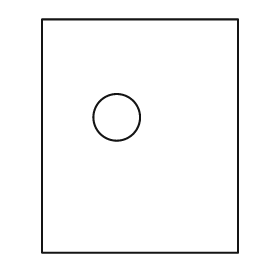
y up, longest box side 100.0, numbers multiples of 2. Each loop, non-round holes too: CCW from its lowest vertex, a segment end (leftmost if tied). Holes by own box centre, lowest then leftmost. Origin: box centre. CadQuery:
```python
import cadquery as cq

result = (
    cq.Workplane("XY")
    .moveTo(-42.0, -50.0)
    .lineTo(42.0, -50.0)
    .lineTo(42.0, 50.0)
    .lineTo(-42.0, 50.0)
    .close()
    .moveTo(-10.0, 8.0)
    .circle(10.0)
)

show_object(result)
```